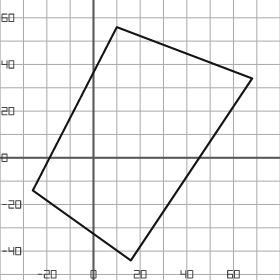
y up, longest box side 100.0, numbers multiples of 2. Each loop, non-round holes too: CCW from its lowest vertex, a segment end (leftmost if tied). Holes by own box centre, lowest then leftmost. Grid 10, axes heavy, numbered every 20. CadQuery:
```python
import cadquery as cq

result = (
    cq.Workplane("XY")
    .moveTo(16.0, -44.0)
    .lineTo(68.0, 34.0)
    .lineTo(10.0, 56.0)
    .lineTo(-26.0, -14.0)
    .close()
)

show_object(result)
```